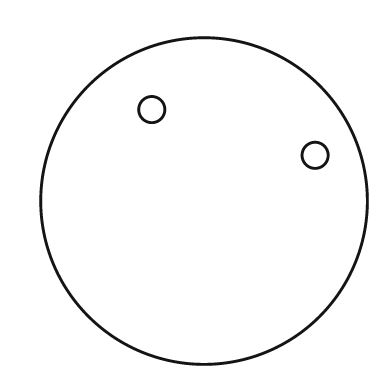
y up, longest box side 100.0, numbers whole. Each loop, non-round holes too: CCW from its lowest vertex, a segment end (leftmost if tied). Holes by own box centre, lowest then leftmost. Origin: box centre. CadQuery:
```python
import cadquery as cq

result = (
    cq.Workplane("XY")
    .moveTo(0.0, 0.0)
    .circle(50.0)
    .moveTo(34.0, 14.0)
    .circle(4.0)
    .moveTo(-16.0, 28.0)
    .circle(4.0)
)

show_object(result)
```